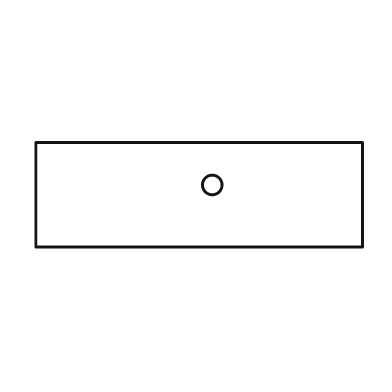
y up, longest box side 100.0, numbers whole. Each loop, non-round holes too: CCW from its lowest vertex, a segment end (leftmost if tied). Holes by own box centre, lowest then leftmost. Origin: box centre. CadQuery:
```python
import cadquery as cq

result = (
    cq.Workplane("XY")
    .moveTo(-50.0, -16.0)
    .lineTo(50.0, -16.0)
    .lineTo(50.0, 16.0)
    .lineTo(-50.0, 16.0)
    .close()
    .moveTo(4.0, 3.0)
    .circle(3.0)
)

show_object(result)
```